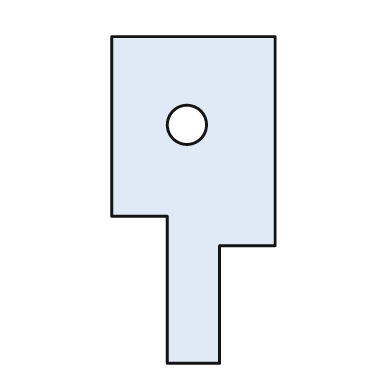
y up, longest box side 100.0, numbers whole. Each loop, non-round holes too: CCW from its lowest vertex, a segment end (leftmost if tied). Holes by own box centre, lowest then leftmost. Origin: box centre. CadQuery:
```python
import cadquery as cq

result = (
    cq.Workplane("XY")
    .moveTo(-8.0, -50.0)
    .lineTo(8.0, -50.0)
    .lineTo(8.0, -14.0)
    .lineTo(25.0, -14.0)
    .lineTo(25.0, 50.0)
    .lineTo(-25.0, 50.0)
    .lineTo(-25.0, -5.0)
    .lineTo(-8.0, -5.0)
    .close()
    .moveTo(-2.0, 23.0)
    .circle(6.0)
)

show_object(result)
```